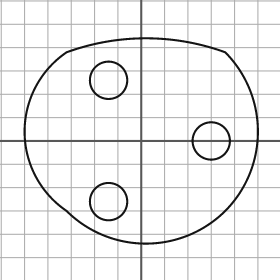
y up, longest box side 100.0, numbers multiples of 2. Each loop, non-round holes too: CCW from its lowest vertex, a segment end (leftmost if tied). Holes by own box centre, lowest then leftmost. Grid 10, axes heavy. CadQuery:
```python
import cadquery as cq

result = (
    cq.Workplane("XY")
    .moveTo(-32.0, -30.0)
    .threePointArc((2.0, -44.0), (36.0, -30.0))
    .threePointArc((50.0, 4.0), (36.0, 38.0))
    .threePointArc((2.0, 44.0), (-32.0, 38.0))
    .threePointArc((-50.0, 4.0), (-32.0, -30.0))
    .close()
    .moveTo(-14.0, -26.0)
    .circle(8.0)
    .moveTo(30.0, 0.0)
    .circle(8.0)
    .moveTo(-14.0, 26.0)
    .circle(8.0)
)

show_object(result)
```